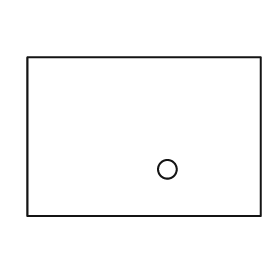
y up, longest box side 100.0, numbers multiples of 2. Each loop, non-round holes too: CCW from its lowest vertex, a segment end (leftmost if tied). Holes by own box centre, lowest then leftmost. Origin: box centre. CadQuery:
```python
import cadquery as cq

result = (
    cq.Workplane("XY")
    .moveTo(-50.0, -34.0)
    .lineTo(50.0, -34.0)
    .lineTo(50.0, 34.0)
    .lineTo(-50.0, 34.0)
    .close()
    .moveTo(10.0, -14.0)
    .circle(4.0)
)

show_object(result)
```